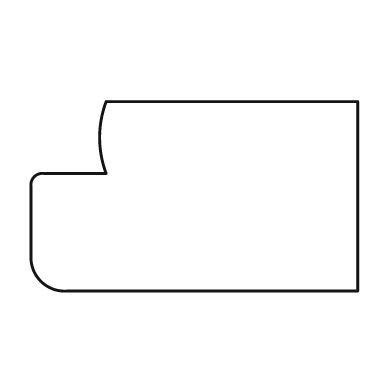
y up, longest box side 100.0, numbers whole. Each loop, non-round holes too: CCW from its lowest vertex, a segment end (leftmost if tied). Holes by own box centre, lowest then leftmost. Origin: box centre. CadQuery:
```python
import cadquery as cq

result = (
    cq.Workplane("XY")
    .moveTo(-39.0, -29.0)
    .lineTo(50.0, -29.0)
    .lineTo(50.0, 29.0)
    .lineTo(-27.0, 29.0)
    .threePointArc((-29.0, 18.0), (-27.0, 7.0))
    .lineTo(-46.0, 7.0)
    .threePointArc((-49.0, 6.0), (-50.0, 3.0))
    .lineTo(-50.0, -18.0)
    .threePointArc((-47.0, -26.0), (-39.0, -29.0))
    .close()
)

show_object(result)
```